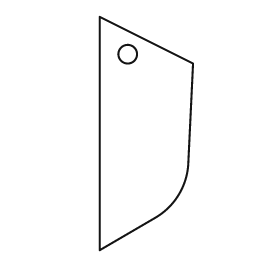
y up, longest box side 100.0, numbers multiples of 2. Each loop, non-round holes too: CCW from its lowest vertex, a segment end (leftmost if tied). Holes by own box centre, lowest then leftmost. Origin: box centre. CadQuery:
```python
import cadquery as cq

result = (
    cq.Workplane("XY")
    .moveTo(-20.0, -50.0)
    .lineTo(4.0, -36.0)
    .threePointArc((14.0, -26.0), (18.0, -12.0))
    .lineTo(20.0, 30.0)
    .lineTo(-20.0, 50.0)
    .close()
    .moveTo(-8.0, 34.0)
    .circle(4.0)
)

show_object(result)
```